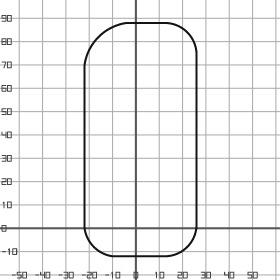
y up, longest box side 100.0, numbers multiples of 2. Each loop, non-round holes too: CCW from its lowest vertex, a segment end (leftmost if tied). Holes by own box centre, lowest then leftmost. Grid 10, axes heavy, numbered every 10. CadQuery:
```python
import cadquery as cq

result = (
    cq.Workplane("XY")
    .moveTo(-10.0, -12.0)
    .lineTo(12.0, -12.0)
    .threePointArc((22.0, -8.0), (26.0, 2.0))
    .lineTo(26.0, 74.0)
    .threePointArc((22.0, 84.0), (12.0, 88.0))
    .lineTo(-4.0, 88.0)
    .threePointArc((-16.0, 82.0), (-22.0, 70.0))
    .lineTo(-22.0, 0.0)
    .threePointArc((-18.0, -8.0), (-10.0, -12.0))
    .close()
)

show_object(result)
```